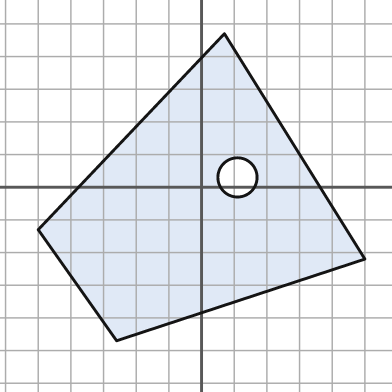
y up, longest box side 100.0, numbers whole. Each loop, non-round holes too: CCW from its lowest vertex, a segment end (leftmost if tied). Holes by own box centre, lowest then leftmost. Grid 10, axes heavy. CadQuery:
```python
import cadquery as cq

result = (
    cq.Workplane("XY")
    .moveTo(-26.0, -47.0)
    .lineTo(50.0, -22.0)
    .lineTo(7.0, 47.0)
    .lineTo(-50.0, -13.0)
    .close()
    .moveTo(11.0, 3.0)
    .circle(6.0)
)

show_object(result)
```